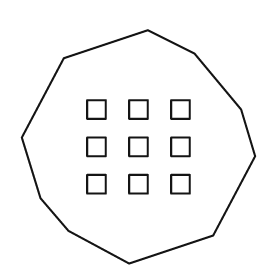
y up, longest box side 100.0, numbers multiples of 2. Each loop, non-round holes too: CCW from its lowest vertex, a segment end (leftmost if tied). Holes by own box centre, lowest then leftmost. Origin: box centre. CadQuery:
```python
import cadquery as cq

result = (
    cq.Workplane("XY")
    .moveTo(-4.0, -50.0)
    .lineTo(32.0, -38.0)
    .lineTo(50.0, -4.0)
    .lineTo(44.0, 16.0)
    .lineTo(24.0, 40.0)
    .lineTo(4.0, 50.0)
    .lineTo(-32.0, 38.0)
    .lineTo(-50.0, 4.0)
    .lineTo(-42.0, -22.0)
    .lineTo(-30.0, -36.0)
    .close()
    .moveTo(-22.0, -20.0)
    .lineTo(-14.0, -20.0)
    .lineTo(-14.0, -12.0)
    .lineTo(-22.0, -12.0)
    .close()
    .moveTo(-4.0, -20.0)
    .lineTo(4.0, -20.0)
    .lineTo(4.0, -12.0)
    .lineTo(-4.0, -12.0)
    .close()
    .moveTo(14.0, -20.0)
    .lineTo(22.0, -20.0)
    .lineTo(22.0, -12.0)
    .lineTo(14.0, -12.0)
    .close()
    .moveTo(-22.0, -4.0)
    .lineTo(-14.0, -4.0)
    .lineTo(-14.0, 4.0)
    .lineTo(-22.0, 4.0)
    .close()
    .moveTo(-4.0, -4.0)
    .lineTo(4.0, -4.0)
    .lineTo(4.0, 4.0)
    .lineTo(-4.0, 4.0)
    .close()
    .moveTo(14.0, -4.0)
    .lineTo(22.0, -4.0)
    .lineTo(22.0, 4.0)
    .lineTo(14.0, 4.0)
    .close()
    .moveTo(-22.0, 12.0)
    .lineTo(-14.0, 12.0)
    .lineTo(-14.0, 20.0)
    .lineTo(-22.0, 20.0)
    .close()
    .moveTo(-4.0, 12.0)
    .lineTo(4.0, 12.0)
    .lineTo(4.0, 20.0)
    .lineTo(-4.0, 20.0)
    .close()
    .moveTo(14.0, 12.0)
    .lineTo(22.0, 12.0)
    .lineTo(22.0, 20.0)
    .lineTo(14.0, 20.0)
    .close()
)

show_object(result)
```